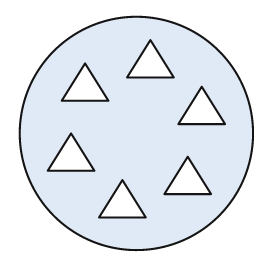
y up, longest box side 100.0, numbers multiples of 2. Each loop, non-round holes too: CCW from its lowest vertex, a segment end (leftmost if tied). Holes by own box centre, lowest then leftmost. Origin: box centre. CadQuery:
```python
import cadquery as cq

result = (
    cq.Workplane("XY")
    .moveTo(0.0, 0.0)
    .circle(50.0)
    .moveTo(-16.0, -36.0)
    .lineTo(4.0, -36.0)
    .lineTo(-6.0, -20.0)
    .close()
    .moveTo(12.0, -26.0)
    .lineTo(32.0, -26.0)
    .lineTo(22.0, -10.0)
    .close()
    .moveTo(-38.0, -16.0)
    .lineTo(-18.0, -16.0)
    .lineTo(-28.0, 0.0)
    .close()
    .moveTo(18.0, 4.0)
    .lineTo(38.0, 4.0)
    .lineTo(28.0, 20.0)
    .close()
    .moveTo(-32.0, 14.0)
    .lineTo(-12.0, 14.0)
    .lineTo(-22.0, 30.0)
    .close()
    .moveTo(-4.0, 24.0)
    .lineTo(16.0, 24.0)
    .lineTo(6.0, 40.0)
    .close()
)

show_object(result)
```